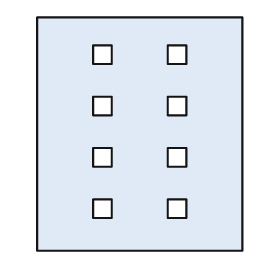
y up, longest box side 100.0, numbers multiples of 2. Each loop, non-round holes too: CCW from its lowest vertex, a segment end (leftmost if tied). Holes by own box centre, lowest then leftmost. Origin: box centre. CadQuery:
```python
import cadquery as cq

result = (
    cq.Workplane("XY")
    .moveTo(-44.0, -50.0)
    .lineTo(44.0, -50.0)
    .lineTo(44.0, 50.0)
    .lineTo(-44.0, 50.0)
    .close()
    .moveTo(-20.0, -36.0)
    .lineTo(-12.0, -36.0)
    .lineTo(-12.0, -28.0)
    .lineTo(-20.0, -28.0)
    .close()
    .moveTo(12.0, -36.0)
    .lineTo(20.0, -36.0)
    .lineTo(20.0, -28.0)
    .lineTo(12.0, -28.0)
    .close()
    .moveTo(-20.0, -14.0)
    .lineTo(-12.0, -14.0)
    .lineTo(-12.0, -6.0)
    .lineTo(-20.0, -6.0)
    .close()
    .moveTo(12.0, -14.0)
    .lineTo(20.0, -14.0)
    .lineTo(20.0, -6.0)
    .lineTo(12.0, -6.0)
    .close()
    .moveTo(-20.0, 8.0)
    .lineTo(-12.0, 8.0)
    .lineTo(-12.0, 16.0)
    .lineTo(-20.0, 16.0)
    .close()
    .moveTo(12.0, 8.0)
    .lineTo(20.0, 8.0)
    .lineTo(20.0, 16.0)
    .lineTo(12.0, 16.0)
    .close()
    .moveTo(-20.0, 30.0)
    .lineTo(-12.0, 30.0)
    .lineTo(-12.0, 38.0)
    .lineTo(-20.0, 38.0)
    .close()
    .moveTo(12.0, 30.0)
    .lineTo(20.0, 30.0)
    .lineTo(20.0, 38.0)
    .lineTo(12.0, 38.0)
    .close()
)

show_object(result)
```